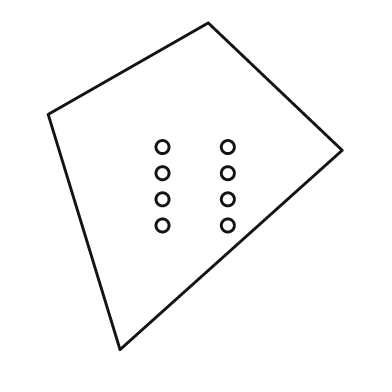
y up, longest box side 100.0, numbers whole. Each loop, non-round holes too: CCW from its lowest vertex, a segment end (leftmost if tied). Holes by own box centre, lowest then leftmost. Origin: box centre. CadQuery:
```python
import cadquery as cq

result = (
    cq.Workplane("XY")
    .moveTo(-23.0, -50.0)
    .lineTo(45.0, 11.0)
    .lineTo(4.0, 50.0)
    .lineTo(-45.0, 22.0)
    .close()
    .moveTo(-10.0, -12.0)
    .circle(2.0)
    .moveTo(10.0, -12.0)
    .circle(2.0)
    .moveTo(-10.0, -4.0)
    .circle(2.0)
    .moveTo(10.0, -4.0)
    .circle(2.0)
    .moveTo(-10.0, 4.0)
    .circle(2.0)
    .moveTo(10.0, 4.0)
    .circle(2.0)
    .moveTo(-10.0, 12.0)
    .circle(2.0)
    .moveTo(10.0, 12.0)
    .circle(2.0)
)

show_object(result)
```